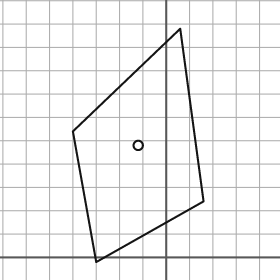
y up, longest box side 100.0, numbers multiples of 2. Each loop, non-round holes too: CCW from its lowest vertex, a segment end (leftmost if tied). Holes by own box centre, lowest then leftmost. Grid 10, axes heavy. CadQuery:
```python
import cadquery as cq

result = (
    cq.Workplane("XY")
    .moveTo(-30.0, -2.0)
    .lineTo(16.0, 24.0)
    .lineTo(6.0, 98.0)
    .lineTo(-40.0, 54.0)
    .close()
    .moveTo(-12.0, 48.0)
    .circle(2.0)
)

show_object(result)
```